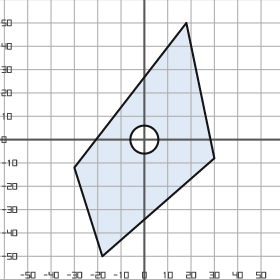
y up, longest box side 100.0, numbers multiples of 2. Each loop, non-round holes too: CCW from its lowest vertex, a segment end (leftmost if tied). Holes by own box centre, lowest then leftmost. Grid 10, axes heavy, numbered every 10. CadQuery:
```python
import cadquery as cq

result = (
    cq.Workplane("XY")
    .moveTo(-18.0, -50.0)
    .lineTo(30.0, -8.0)
    .lineTo(18.0, 50.0)
    .lineTo(-30.0, -12.0)
    .close()
    .moveTo(0.0, 0.0)
    .circle(6.0)
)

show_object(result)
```